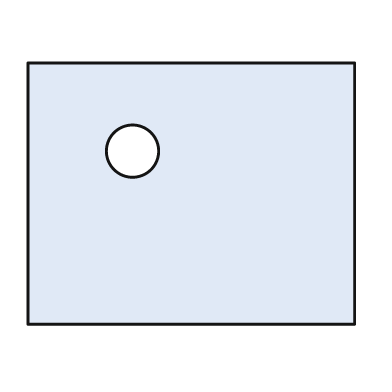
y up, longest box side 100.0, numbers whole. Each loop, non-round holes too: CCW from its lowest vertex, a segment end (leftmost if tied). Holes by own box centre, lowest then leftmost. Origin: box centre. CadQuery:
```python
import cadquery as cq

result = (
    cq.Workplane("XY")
    .moveTo(-50.0, -40.0)
    .lineTo(50.0, -40.0)
    .lineTo(50.0, 40.0)
    .lineTo(-50.0, 40.0)
    .close()
    .moveTo(-18.0, 13.0)
    .circle(8.0)
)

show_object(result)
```